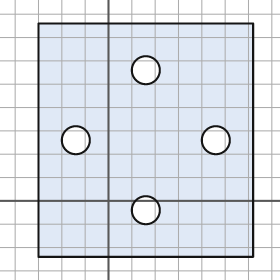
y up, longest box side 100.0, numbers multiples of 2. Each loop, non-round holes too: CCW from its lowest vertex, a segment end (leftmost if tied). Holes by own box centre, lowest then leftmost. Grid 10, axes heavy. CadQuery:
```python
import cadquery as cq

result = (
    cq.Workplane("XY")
    .moveTo(-30.0, -24.0)
    .lineTo(62.0, -24.0)
    .lineTo(62.0, 76.0)
    .lineTo(-30.0, 76.0)
    .close()
    .moveTo(16.0, -4.0)
    .circle(6.0)
    .moveTo(-14.0, 26.0)
    .circle(6.0)
    .moveTo(46.0, 26.0)
    .circle(6.0)
    .moveTo(16.0, 56.0)
    .circle(6.0)
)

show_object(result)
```